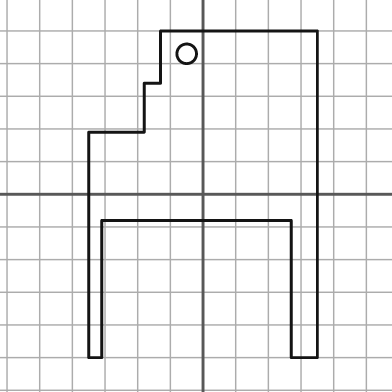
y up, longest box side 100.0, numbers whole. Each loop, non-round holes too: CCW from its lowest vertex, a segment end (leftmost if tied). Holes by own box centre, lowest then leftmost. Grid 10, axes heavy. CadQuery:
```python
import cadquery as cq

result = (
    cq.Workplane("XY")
    .moveTo(-35.0, -50.0)
    .lineTo(-31.0, -50.0)
    .lineTo(-31.0, -8.0)
    .lineTo(27.0, -8.0)
    .lineTo(27.0, -50.0)
    .lineTo(35.0, -50.0)
    .lineTo(35.0, 50.0)
    .lineTo(-13.0, 50.0)
    .lineTo(-13.0, 34.0)
    .lineTo(-18.0, 34.0)
    .lineTo(-18.0, 19.0)
    .lineTo(-35.0, 19.0)
    .close()
    .moveTo(-5.0, 43.0)
    .circle(3.0)
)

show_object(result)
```